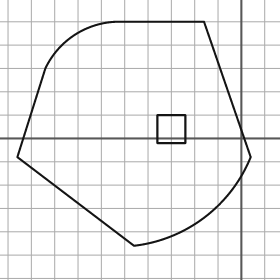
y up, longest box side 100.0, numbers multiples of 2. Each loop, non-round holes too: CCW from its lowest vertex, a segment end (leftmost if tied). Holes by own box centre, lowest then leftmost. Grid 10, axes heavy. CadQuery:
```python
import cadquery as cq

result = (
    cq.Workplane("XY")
    .moveTo(-46.0, -46.0)
    .threePointArc((-16.0, -34.0), (4.0, -8.0))
    .lineTo(-16.0, 50.0)
    .lineTo(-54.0, 50.0)
    .threePointArc((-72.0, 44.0), (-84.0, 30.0))
    .lineTo(-96.0, -8.0)
    .close()
    .moveTo(-36.0, -2.0)
    .lineTo(-24.0, -2.0)
    .lineTo(-24.0, 10.0)
    .lineTo(-36.0, 10.0)
    .close()
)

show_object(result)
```